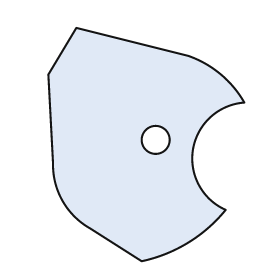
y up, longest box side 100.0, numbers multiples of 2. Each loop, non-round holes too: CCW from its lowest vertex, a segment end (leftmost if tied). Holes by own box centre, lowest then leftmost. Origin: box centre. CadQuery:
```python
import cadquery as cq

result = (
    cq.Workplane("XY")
    .moveTo(-2.0, -50.0)
    .threePointArc((18.0, -42.0), (34.0, -28.0))
    .threePointArc((20.0, -2.0), (42.0, 18.0))
    .threePointArc((32.0, 30.0), (18.0, 38.0))
    .lineTo(-30.0, 50.0)
    .lineTo(-42.0, 30.0)
    .lineTo(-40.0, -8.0)
    .threePointArc((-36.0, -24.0), (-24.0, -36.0))
    .close()
    .moveTo(4.0, 2.0)
    .circle(6.0)
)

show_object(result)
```